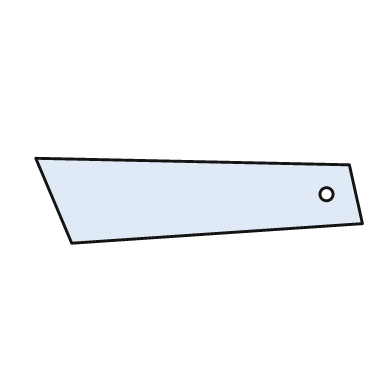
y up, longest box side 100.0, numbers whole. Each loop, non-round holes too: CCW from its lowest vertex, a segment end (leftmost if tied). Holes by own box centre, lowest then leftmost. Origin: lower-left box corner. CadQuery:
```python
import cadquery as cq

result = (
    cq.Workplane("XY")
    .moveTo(11.0, 0.0)
    .lineTo(100.0, 6.0)
    .lineTo(96.0, 24.0)
    .lineTo(0.0, 26.0)
    .close()
    .moveTo(89.0, 15.0)
    .circle(2.0)
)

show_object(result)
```